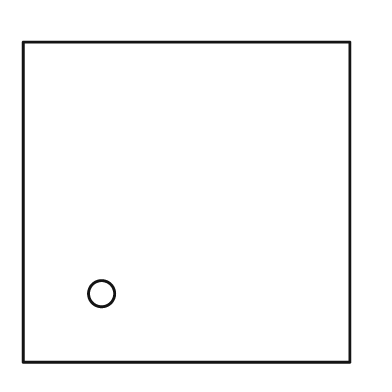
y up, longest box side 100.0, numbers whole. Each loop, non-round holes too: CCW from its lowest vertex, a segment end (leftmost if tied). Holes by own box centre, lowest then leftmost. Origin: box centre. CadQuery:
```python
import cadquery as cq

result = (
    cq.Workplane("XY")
    .moveTo(-50.0, -49.0)
    .lineTo(50.0, -49.0)
    .lineTo(50.0, 49.0)
    .lineTo(-50.0, 49.0)
    .close()
    .moveTo(-26.0, -28.0)
    .circle(4.0)
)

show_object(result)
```